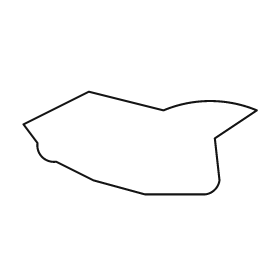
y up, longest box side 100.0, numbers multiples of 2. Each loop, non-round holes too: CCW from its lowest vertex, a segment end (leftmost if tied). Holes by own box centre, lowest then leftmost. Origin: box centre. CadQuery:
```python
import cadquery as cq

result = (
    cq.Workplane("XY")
    .moveTo(2.0, -22.0)
    .lineTo(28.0, -22.0)
    .threePointArc((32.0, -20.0), (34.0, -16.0))
    .lineTo(32.0, 2.0)
    .lineTo(50.0, 14.0)
    .threePointArc((30.0, 18.0), (10.0, 14.0))
    .lineTo(-22.0, 22.0)
    .lineTo(-50.0, 8.0)
    .lineTo(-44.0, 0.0)
    .threePointArc((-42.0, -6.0), (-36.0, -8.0))
    .lineTo(-20.0, -16.0)
    .close()
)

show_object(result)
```